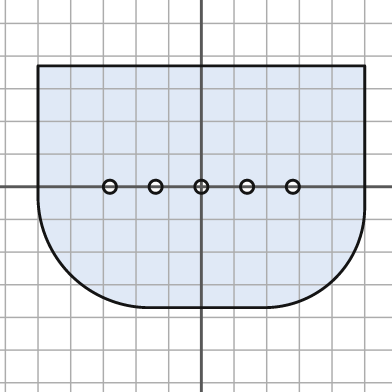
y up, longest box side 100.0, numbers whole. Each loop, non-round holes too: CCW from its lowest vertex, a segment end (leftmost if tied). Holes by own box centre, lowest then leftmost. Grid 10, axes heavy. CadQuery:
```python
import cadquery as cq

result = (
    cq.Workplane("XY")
    .moveTo(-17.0, -37.0)
    .lineTo(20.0, -37.0)
    .threePointArc((41.0, -28.0), (50.0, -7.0))
    .lineTo(50.0, 37.0)
    .lineTo(-50.0, 37.0)
    .lineTo(-50.0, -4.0)
    .threePointArc((-40.0, -27.0), (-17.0, -37.0))
    .close()
    .moveTo(-28.0, 0.0)
    .circle(2.0)
    .moveTo(-14.0, 0.0)
    .circle(2.0)
    .moveTo(0.0, 0.0)
    .circle(2.0)
    .moveTo(14.0, 0.0)
    .circle(2.0)
    .moveTo(28.0, 0.0)
    .circle(2.0)
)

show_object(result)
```